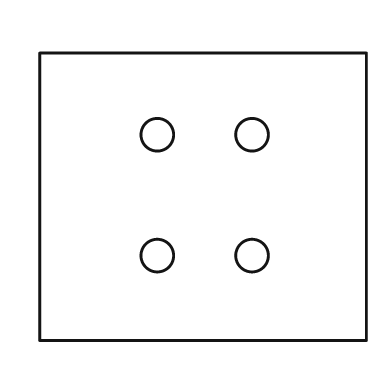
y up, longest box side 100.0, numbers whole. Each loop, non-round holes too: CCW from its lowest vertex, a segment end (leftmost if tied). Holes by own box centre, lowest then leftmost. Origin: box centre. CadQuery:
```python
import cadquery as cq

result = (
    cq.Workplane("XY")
    .moveTo(-50.0, -44.0)
    .lineTo(50.0, -44.0)
    .lineTo(50.0, 44.0)
    .lineTo(-50.0, 44.0)
    .close()
    .moveTo(-14.0, -18.0)
    .circle(5.0)
    .moveTo(15.0, -18.0)
    .circle(5.0)
    .moveTo(-14.0, 19.0)
    .circle(5.0)
    .moveTo(15.0, 19.0)
    .circle(5.0)
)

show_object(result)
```